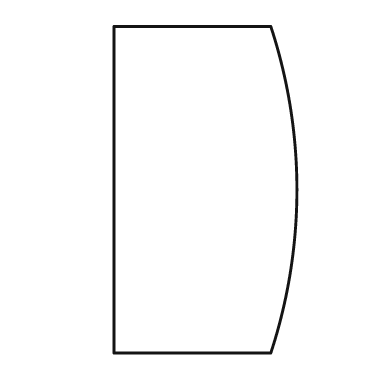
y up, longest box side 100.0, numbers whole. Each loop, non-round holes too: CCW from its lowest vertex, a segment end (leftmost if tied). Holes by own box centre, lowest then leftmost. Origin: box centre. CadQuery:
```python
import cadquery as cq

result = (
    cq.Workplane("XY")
    .moveTo(-28.0, -50.0)
    .lineTo(20.0, -50.0)
    .threePointArc((28.0, 0.0), (20.0, 50.0))
    .lineTo(-28.0, 50.0)
    .close()
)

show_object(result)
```